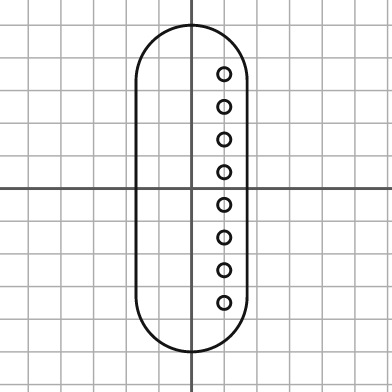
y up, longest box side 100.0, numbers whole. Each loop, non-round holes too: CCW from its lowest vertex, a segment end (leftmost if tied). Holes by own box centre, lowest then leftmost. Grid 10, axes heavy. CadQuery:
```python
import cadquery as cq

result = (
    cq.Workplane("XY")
    .moveTo(-17.0, -33.0)
    .threePointArc((0.0, -50.0), (17.0, -33.0))
    .lineTo(17.0, 33.0)
    .threePointArc((0.0, 50.0), (-17.0, 33.0))
    .close()
    .moveTo(10.0, -35.0)
    .circle(2.0)
    .moveTo(10.0, -25.0)
    .circle(2.0)
    .moveTo(10.0, -15.0)
    .circle(2.0)
    .moveTo(10.0, -5.0)
    .circle(2.0)
    .moveTo(10.0, 5.0)
    .circle(2.0)
    .moveTo(10.0, 15.0)
    .circle(2.0)
    .moveTo(10.0, 25.0)
    .circle(2.0)
    .moveTo(10.0, 35.0)
    .circle(2.0)
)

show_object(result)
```